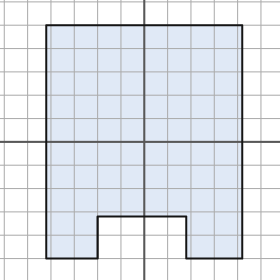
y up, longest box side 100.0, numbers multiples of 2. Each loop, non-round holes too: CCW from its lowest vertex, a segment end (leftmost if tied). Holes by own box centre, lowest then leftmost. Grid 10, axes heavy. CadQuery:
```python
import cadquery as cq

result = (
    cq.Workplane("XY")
    .moveTo(-42.0, -50.0)
    .lineTo(-20.0, -50.0)
    .lineTo(-20.0, -32.0)
    .lineTo(18.0, -32.0)
    .lineTo(18.0, -50.0)
    .lineTo(42.0, -50.0)
    .lineTo(42.0, 50.0)
    .lineTo(-42.0, 50.0)
    .close()
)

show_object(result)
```